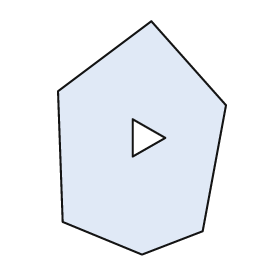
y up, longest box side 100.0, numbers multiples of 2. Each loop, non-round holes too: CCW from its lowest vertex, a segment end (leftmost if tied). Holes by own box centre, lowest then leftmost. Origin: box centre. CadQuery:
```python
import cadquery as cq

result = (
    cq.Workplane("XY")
    .moveTo(0.0, -50.0)
    .lineTo(26.0, -40.0)
    .lineTo(36.0, 14.0)
    .lineTo(4.0, 50.0)
    .lineTo(-36.0, 20.0)
    .lineTo(-34.0, -36.0)
    .close()
    .moveTo(-4.0, -8.0)
    .lineTo(10.0, 0.0)
    .lineTo(-4.0, 8.0)
    .close()
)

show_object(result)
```